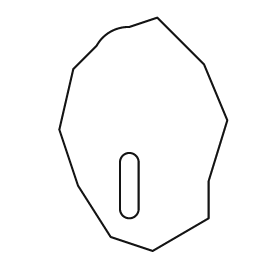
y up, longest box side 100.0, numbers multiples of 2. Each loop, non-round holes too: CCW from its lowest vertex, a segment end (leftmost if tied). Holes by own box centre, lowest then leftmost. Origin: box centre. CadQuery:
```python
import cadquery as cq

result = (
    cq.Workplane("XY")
    .moveTo(4.0, -50.0)
    .lineTo(28.0, -36.0)
    .lineTo(28.0, -20.0)
    .lineTo(36.0, 6.0)
    .lineTo(26.0, 30.0)
    .lineTo(6.0, 50.0)
    .lineTo(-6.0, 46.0)
    .threePointArc((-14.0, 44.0), (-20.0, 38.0))
    .lineTo(-30.0, 28.0)
    .lineTo(-36.0, 2.0)
    .lineTo(-28.0, -22.0)
    .lineTo(-14.0, -44.0)
    .close()
    .moveTo(-10.0, -32.0)
    .threePointArc((-6.0, -36.0), (-2.0, -32.0))
    .lineTo(-2.0, -12.0)
    .threePointArc((-6.0, -8.0), (-10.0, -12.0))
    .close()
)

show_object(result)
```